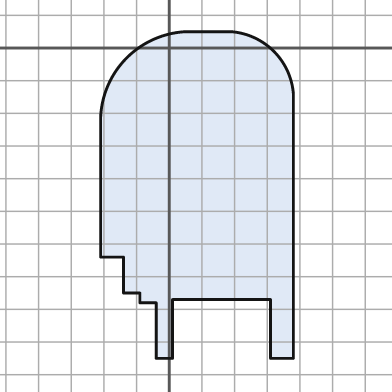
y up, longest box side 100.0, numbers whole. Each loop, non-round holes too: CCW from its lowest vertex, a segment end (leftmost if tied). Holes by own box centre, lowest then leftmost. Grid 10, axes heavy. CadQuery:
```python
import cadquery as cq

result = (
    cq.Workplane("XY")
    .moveTo(-4.0, -95.0)
    .lineTo(1.0, -95.0)
    .lineTo(1.0, -77.0)
    .lineTo(31.0, -77.0)
    .lineTo(31.0, -95.0)
    .lineTo(38.0, -95.0)
    .lineTo(38.0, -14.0)
    .threePointArc((32.0, -1.0), (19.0, 5.0))
    .lineTo(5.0, 5.0)
    .threePointArc((-13.0, -3.0), (-21.0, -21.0))
    .lineTo(-21.0, -64.0)
    .lineTo(-14.0, -64.0)
    .lineTo(-14.0, -75.0)
    .lineTo(-9.0, -75.0)
    .lineTo(-9.0, -78.0)
    .lineTo(-4.0, -78.0)
    .close()
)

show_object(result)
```